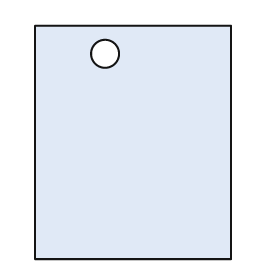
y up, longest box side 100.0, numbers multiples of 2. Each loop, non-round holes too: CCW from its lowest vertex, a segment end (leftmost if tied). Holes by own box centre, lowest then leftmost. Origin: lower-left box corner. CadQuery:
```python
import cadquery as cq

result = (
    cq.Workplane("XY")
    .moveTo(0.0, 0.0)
    .lineTo(84.0, 0.0)
    .lineTo(84.0, 100.0)
    .lineTo(0.0, 100.0)
    .close()
    .moveTo(30.0, 88.0)
    .circle(6.0)
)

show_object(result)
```